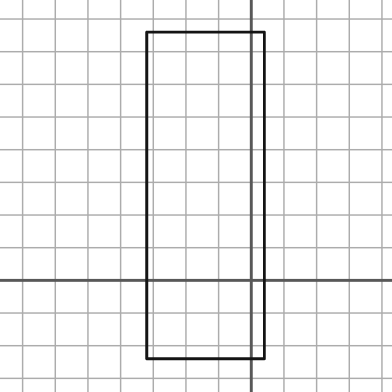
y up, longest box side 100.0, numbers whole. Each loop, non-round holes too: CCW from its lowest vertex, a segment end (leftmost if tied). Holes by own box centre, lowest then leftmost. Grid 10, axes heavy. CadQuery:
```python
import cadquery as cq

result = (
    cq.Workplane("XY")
    .moveTo(-32.0, -24.0)
    .lineTo(4.0, -24.0)
    .lineTo(4.0, 76.0)
    .lineTo(-32.0, 76.0)
    .close()
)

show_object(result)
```